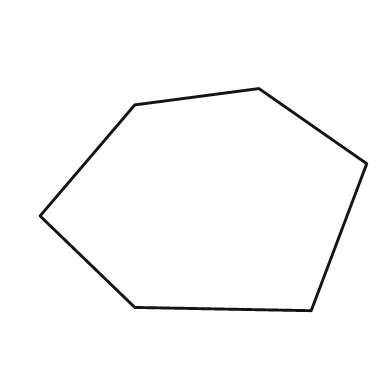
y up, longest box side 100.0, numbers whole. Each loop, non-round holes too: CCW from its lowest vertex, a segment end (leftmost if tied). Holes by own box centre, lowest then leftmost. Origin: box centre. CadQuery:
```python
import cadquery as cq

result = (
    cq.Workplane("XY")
    .moveTo(33.0, -34.0)
    .lineTo(50.0, 11.0)
    .lineTo(17.0, 34.0)
    .lineTo(-21.0, 29.0)
    .lineTo(-50.0, -5.0)
    .lineTo(-21.0, -33.0)
    .close()
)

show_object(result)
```